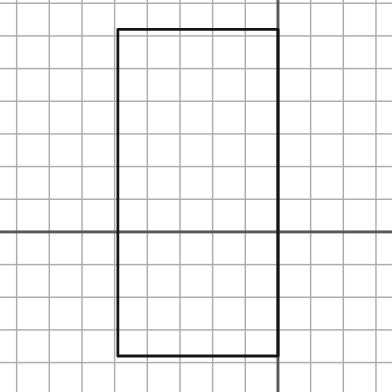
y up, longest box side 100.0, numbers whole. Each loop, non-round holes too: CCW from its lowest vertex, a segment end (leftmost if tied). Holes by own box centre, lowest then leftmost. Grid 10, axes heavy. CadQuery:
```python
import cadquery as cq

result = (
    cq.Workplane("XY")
    .moveTo(-49.0, -38.0)
    .lineTo(0.0, -38.0)
    .lineTo(0.0, 62.0)
    .lineTo(-49.0, 62.0)
    .close()
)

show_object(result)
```